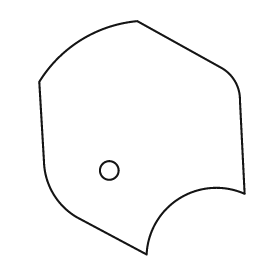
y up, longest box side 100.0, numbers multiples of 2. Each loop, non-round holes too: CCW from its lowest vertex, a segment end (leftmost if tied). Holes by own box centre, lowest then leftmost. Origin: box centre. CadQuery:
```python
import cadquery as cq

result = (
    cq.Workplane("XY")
    .moveTo(2.0, -50.0)
    .threePointArc((16.0, -26.0), (44.0, -24.0))
    .lineTo(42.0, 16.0)
    .threePointArc((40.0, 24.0), (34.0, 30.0))
    .lineTo(-2.0, 50.0)
    .threePointArc((-26.0, 42.0), (-44.0, 24.0))
    .lineTo(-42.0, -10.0)
    .threePointArc((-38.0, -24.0), (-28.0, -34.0))
    .close()
    .moveTo(-14.0, -14.0)
    .circle(4.0)
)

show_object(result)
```